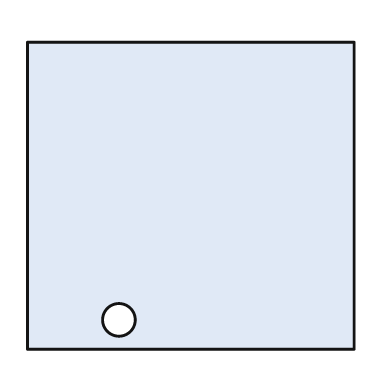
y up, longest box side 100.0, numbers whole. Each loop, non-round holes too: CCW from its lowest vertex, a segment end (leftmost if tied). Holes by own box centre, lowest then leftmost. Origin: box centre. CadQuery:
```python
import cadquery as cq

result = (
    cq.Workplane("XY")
    .moveTo(-50.0, -47.0)
    .lineTo(50.0, -47.0)
    .lineTo(50.0, 47.0)
    .lineTo(-50.0, 47.0)
    .close()
    .moveTo(-22.0, -38.0)
    .circle(5.0)
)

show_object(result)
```